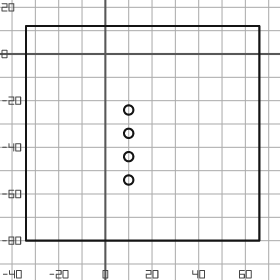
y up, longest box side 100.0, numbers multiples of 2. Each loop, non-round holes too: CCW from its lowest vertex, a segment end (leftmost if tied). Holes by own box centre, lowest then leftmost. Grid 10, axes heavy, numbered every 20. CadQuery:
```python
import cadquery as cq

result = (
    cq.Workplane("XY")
    .moveTo(-34.0, -80.0)
    .lineTo(66.0, -80.0)
    .lineTo(66.0, 12.0)
    .lineTo(-34.0, 12.0)
    .close()
    .moveTo(10.0, -54.0)
    .circle(2.0)
    .moveTo(10.0, -44.0)
    .circle(2.0)
    .moveTo(10.0, -34.0)
    .circle(2.0)
    .moveTo(10.0, -24.0)
    .circle(2.0)
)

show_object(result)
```